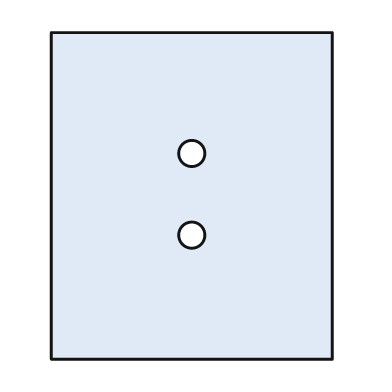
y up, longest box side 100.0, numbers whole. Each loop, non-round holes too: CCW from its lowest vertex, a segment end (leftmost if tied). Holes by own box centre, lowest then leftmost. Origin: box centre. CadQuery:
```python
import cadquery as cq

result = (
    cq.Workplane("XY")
    .moveTo(-43.0, -50.0)
    .lineTo(43.0, -50.0)
    .lineTo(43.0, 50.0)
    .lineTo(-43.0, 50.0)
    .close()
    .moveTo(0.0, -12.0)
    .circle(4.0)
    .moveTo(0.0, 13.0)
    .circle(4.0)
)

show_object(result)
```